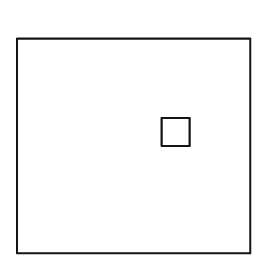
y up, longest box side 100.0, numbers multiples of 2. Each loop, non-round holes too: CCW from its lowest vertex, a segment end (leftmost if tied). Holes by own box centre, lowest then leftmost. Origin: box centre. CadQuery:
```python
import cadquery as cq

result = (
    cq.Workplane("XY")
    .moveTo(-50.0, -46.0)
    .lineTo(50.0, -46.0)
    .lineTo(50.0, 46.0)
    .lineTo(-50.0, 46.0)
    .close()
    .moveTo(12.0, 0.0)
    .lineTo(24.0, 0.0)
    .lineTo(24.0, 12.0)
    .lineTo(12.0, 12.0)
    .close()
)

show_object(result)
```